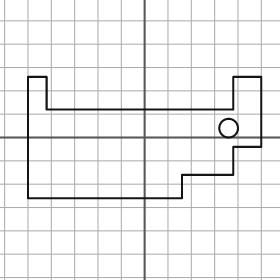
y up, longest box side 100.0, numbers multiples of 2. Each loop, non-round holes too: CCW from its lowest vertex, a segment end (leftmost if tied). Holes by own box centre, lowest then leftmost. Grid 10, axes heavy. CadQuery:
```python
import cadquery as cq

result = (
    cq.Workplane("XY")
    .moveTo(-50.0, -26.0)
    .lineTo(16.0, -26.0)
    .lineTo(16.0, -16.0)
    .lineTo(38.0, -16.0)
    .lineTo(38.0, -4.0)
    .lineTo(50.0, -4.0)
    .lineTo(50.0, 26.0)
    .lineTo(38.0, 26.0)
    .lineTo(38.0, 12.0)
    .lineTo(-42.0, 12.0)
    .lineTo(-42.0, 26.0)
    .lineTo(-50.0, 26.0)
    .close()
    .moveTo(36.0, 4.0)
    .circle(4.0)
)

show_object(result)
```